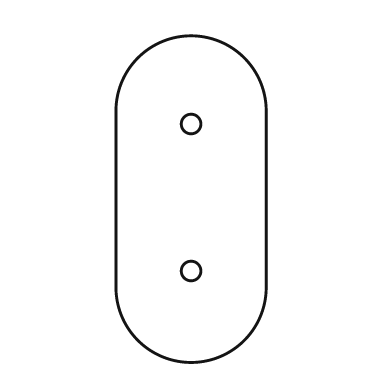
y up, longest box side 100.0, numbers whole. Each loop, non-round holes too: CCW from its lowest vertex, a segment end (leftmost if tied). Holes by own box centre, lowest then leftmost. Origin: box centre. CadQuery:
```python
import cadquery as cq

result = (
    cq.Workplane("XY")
    .moveTo(-23.0, -27.0)
    .threePointArc((0.0, -50.0), (23.0, -27.0))
    .lineTo(23.0, 27.0)
    .threePointArc((0.0, 50.0), (-23.0, 27.0))
    .close()
    .moveTo(0.0, -22.0)
    .circle(3.0)
    .moveTo(0.0, 23.0)
    .circle(3.0)
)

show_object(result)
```